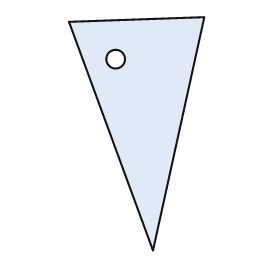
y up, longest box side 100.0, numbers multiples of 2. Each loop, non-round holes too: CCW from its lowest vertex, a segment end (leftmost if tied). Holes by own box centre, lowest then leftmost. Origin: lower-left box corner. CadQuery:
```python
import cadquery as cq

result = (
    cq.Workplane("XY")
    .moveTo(36.0, 0.0)
    .lineTo(58.0, 100.0)
    .lineTo(0.0, 98.0)
    .close()
    .moveTo(20.0, 82.0)
    .circle(4.0)
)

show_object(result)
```